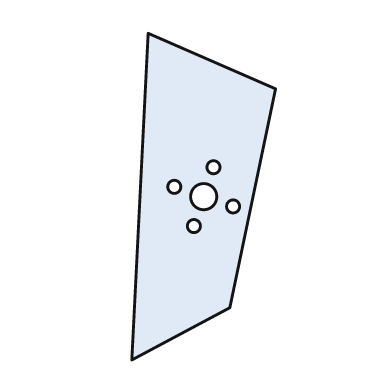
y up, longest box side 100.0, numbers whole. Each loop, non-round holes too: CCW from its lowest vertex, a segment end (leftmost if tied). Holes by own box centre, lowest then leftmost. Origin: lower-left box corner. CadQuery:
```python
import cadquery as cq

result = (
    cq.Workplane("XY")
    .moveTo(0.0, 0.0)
    .lineTo(30.0, 16.0)
    .lineTo(44.0, 83.0)
    .lineTo(5.0, 100.0)
    .close()
    .moveTo(19.0, 41.0)
    .circle(2.0)
    .moveTo(31.0, 47.0)
    .circle(2.0)
    .moveTo(22.0, 50.0)
    .circle(4.0)
    .moveTo(13.0, 53.0)
    .circle(2.0)
    .moveTo(25.0, 59.0)
    .circle(2.0)
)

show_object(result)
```